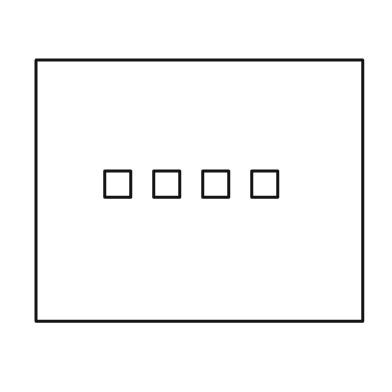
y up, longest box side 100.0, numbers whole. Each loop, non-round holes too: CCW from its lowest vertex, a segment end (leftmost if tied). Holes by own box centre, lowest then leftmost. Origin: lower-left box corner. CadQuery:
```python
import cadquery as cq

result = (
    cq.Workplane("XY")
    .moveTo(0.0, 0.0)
    .lineTo(100.0, 0.0)
    .lineTo(100.0, 80.0)
    .lineTo(0.0, 80.0)
    .close()
    .moveTo(21.0, 38.0)
    .lineTo(29.0, 38.0)
    .lineTo(29.0, 46.0)
    .lineTo(21.0, 46.0)
    .close()
    .moveTo(36.0, 38.0)
    .lineTo(44.0, 38.0)
    .lineTo(44.0, 46.0)
    .lineTo(36.0, 46.0)
    .close()
    .moveTo(51.0, 38.0)
    .lineTo(59.0, 38.0)
    .lineTo(59.0, 46.0)
    .lineTo(51.0, 46.0)
    .close()
    .moveTo(66.0, 38.0)
    .lineTo(74.0, 38.0)
    .lineTo(74.0, 46.0)
    .lineTo(66.0, 46.0)
    .close()
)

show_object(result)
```